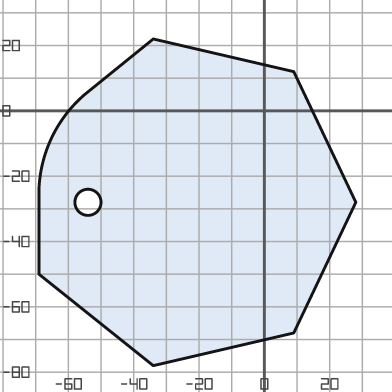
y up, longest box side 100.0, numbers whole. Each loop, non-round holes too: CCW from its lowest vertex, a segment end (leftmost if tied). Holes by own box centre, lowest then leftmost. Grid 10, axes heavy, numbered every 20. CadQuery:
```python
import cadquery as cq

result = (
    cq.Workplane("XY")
    .moveTo(-34.0, -78.0)
    .lineTo(9.0, -68.0)
    .lineTo(28.0, -28.0)
    .lineTo(9.0, 12.0)
    .lineTo(-34.0, 22.0)
    .lineTo(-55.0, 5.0)
    .threePointArc((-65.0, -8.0), (-69.0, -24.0))
    .lineTo(-69.0, -50.0)
    .close()
    .moveTo(-54.0, -28.0)
    .circle(4.0)
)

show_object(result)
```